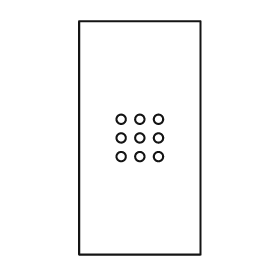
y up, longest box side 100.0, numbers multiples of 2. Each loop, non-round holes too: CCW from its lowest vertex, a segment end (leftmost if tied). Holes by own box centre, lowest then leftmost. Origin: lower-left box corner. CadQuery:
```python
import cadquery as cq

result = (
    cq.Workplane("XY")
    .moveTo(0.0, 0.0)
    .lineTo(52.0, 0.0)
    .lineTo(52.0, 100.0)
    .lineTo(0.0, 100.0)
    .close()
    .moveTo(18.0, 42.0)
    .circle(2.0)
    .moveTo(26.0, 42.0)
    .circle(2.0)
    .moveTo(34.0, 42.0)
    .circle(2.0)
    .moveTo(18.0, 50.0)
    .circle(2.0)
    .moveTo(26.0, 50.0)
    .circle(2.0)
    .moveTo(34.0, 50.0)
    .circle(2.0)
    .moveTo(18.0, 58.0)
    .circle(2.0)
    .moveTo(26.0, 58.0)
    .circle(2.0)
    .moveTo(34.0, 58.0)
    .circle(2.0)
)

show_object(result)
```